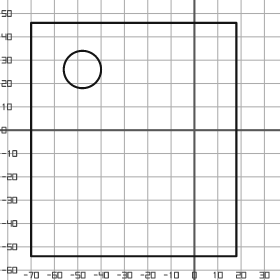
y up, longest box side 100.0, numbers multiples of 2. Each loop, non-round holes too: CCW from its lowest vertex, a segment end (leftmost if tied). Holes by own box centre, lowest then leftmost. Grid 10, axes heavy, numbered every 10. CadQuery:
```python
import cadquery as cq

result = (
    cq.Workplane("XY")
    .moveTo(-70.0, -54.0)
    .lineTo(18.0, -54.0)
    .lineTo(18.0, 46.0)
    .lineTo(-70.0, 46.0)
    .close()
    .moveTo(-48.0, 26.0)
    .circle(8.0)
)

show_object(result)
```